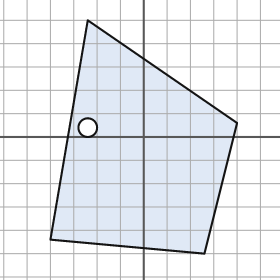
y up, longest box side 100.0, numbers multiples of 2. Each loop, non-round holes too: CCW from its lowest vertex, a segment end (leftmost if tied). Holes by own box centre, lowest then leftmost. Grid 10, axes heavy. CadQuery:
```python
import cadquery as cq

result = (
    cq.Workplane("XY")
    .moveTo(26.0, -50.0)
    .lineTo(40.0, 6.0)
    .lineTo(-24.0, 50.0)
    .lineTo(-40.0, -44.0)
    .close()
    .moveTo(-24.0, 4.0)
    .circle(4.0)
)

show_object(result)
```